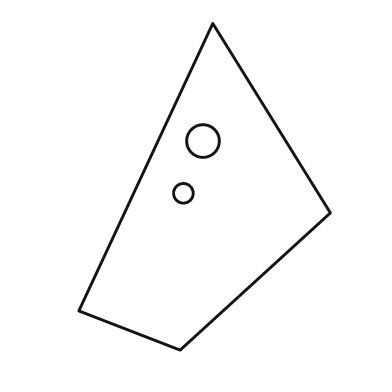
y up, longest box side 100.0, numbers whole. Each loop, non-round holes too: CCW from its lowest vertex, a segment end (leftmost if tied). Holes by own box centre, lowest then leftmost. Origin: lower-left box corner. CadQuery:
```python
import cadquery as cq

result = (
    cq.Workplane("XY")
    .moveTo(31.0, 0.0)
    .lineTo(77.0, 42.0)
    .lineTo(41.0, 100.0)
    .lineTo(0.0, 12.0)
    .close()
    .moveTo(32.0, 48.0)
    .circle(3.0)
    .moveTo(38.0, 64.0)
    .circle(5.0)
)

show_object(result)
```